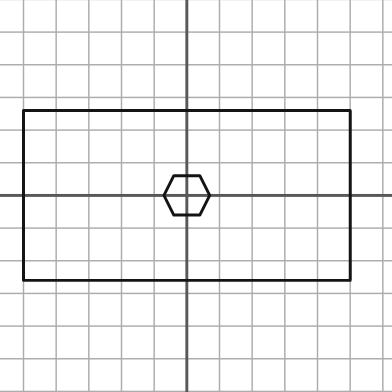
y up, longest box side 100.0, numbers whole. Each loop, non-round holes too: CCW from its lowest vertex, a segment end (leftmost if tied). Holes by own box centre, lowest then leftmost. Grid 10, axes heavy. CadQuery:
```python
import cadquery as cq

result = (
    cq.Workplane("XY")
    .moveTo(-50.0, -26.0)
    .lineTo(50.0, -26.0)
    .lineTo(50.0, 26.0)
    .lineTo(-50.0, 26.0)
    .close()
    .moveTo(-4.0, -6.0)
    .lineTo(4.0, -6.0)
    .lineTo(7.0, 0.0)
    .lineTo(4.0, 6.0)
    .lineTo(-4.0, 6.0)
    .lineTo(-7.0, 0.0)
    .close()
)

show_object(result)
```